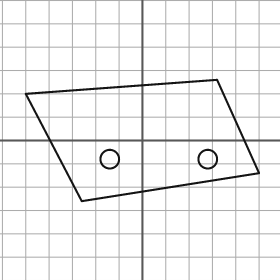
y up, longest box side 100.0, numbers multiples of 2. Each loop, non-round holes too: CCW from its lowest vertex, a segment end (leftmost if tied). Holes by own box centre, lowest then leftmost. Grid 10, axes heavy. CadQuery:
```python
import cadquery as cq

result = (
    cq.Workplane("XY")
    .moveTo(-26.0, -26.0)
    .lineTo(50.0, -14.0)
    .lineTo(32.0, 26.0)
    .lineTo(-50.0, 20.0)
    .close()
    .moveTo(-14.0, -8.0)
    .circle(4.0)
    .moveTo(28.0, -8.0)
    .circle(4.0)
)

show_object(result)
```